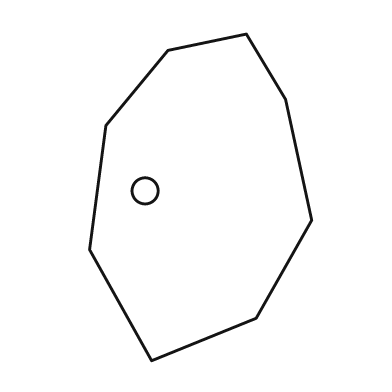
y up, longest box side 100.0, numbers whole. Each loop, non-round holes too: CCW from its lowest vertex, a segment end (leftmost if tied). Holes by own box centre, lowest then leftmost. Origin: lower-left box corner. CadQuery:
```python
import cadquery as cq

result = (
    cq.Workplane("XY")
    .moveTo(19.0, 0.0)
    .lineTo(51.0, 13.0)
    .lineTo(68.0, 43.0)
    .lineTo(60.0, 80.0)
    .lineTo(48.0, 100.0)
    .lineTo(24.0, 95.0)
    .lineTo(5.0, 72.0)
    .lineTo(0.0, 34.0)
    .close()
    .moveTo(17.0, 52.0)
    .circle(4.0)
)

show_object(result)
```